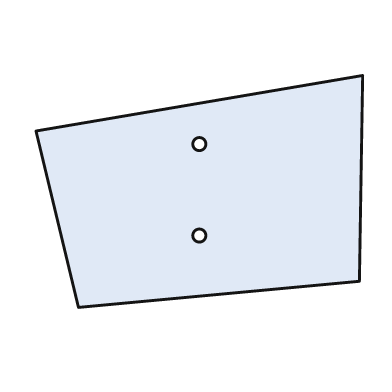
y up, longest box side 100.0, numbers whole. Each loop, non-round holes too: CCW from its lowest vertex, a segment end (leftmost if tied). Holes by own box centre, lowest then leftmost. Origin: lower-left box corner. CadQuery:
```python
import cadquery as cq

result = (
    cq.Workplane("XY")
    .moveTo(13.0, 0.0)
    .lineTo(99.0, 8.0)
    .lineTo(100.0, 71.0)
    .lineTo(0.0, 54.0)
    .close()
    .moveTo(50.0, 22.0)
    .circle(2.0)
    .moveTo(50.0, 50.0)
    .circle(2.0)
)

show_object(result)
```